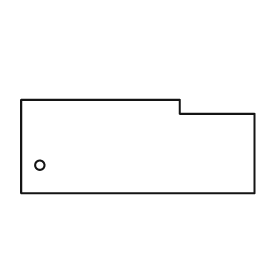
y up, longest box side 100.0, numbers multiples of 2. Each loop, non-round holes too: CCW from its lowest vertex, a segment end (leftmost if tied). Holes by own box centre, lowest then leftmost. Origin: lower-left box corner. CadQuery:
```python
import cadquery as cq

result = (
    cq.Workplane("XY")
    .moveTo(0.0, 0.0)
    .lineTo(100.0, 0.0)
    .lineTo(100.0, 34.0)
    .lineTo(68.0, 34.0)
    .lineTo(68.0, 40.0)
    .lineTo(0.0, 40.0)
    .close()
    .moveTo(8.0, 12.0)
    .circle(2.0)
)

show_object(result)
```